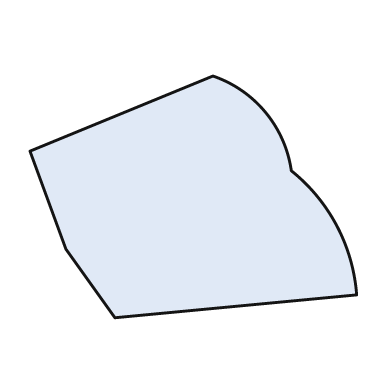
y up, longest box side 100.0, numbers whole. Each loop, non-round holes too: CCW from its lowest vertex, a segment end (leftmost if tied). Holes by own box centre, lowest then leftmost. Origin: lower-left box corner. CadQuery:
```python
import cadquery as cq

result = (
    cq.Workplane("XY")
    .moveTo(26.0, 0.0)
    .lineTo(100.0, 7.0)
    .threePointArc((94.0, 28.0), (80.0, 45.0))
    .threePointArc((72.0, 63.0), (56.0, 74.0))
    .lineTo(0.0, 51.0)
    .lineTo(11.0, 21.0)
    .close()
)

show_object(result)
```